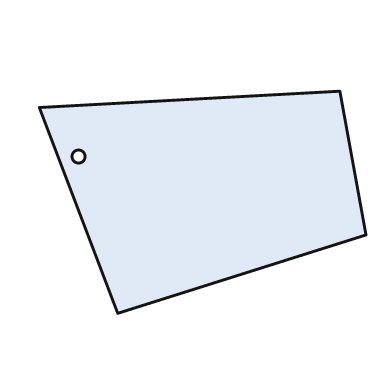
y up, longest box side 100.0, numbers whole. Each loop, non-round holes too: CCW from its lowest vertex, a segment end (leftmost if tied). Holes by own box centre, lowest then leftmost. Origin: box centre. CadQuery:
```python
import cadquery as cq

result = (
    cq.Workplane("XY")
    .moveTo(-26.0, -34.0)
    .lineTo(50.0, -10.0)
    .lineTo(42.0, 34.0)
    .lineTo(-50.0, 29.0)
    .close()
    .moveTo(-38.0, 14.0)
    .circle(2.0)
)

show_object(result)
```